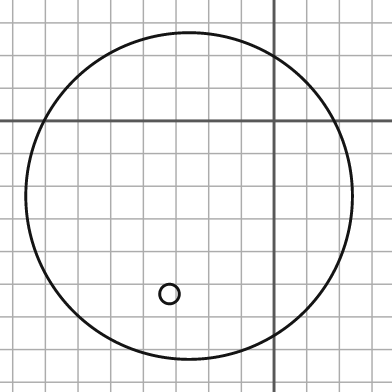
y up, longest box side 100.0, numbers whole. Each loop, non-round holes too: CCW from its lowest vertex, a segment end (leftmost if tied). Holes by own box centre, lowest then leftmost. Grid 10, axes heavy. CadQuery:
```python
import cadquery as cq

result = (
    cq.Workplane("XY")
    .moveTo(-26.0, -23.0)
    .circle(50.0)
    .moveTo(-32.0, -53.0)
    .circle(3.0)
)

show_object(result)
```